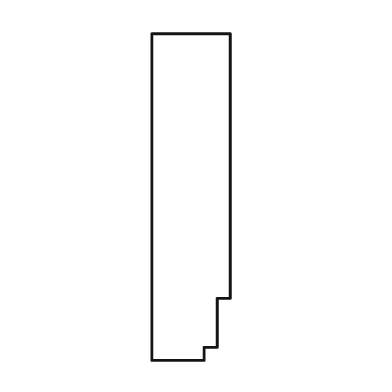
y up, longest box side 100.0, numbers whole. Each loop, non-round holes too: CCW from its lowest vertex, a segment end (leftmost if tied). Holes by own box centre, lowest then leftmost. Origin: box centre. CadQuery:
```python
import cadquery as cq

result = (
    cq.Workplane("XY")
    .moveTo(-12.0, -50.0)
    .lineTo(4.0, -50.0)
    .lineTo(4.0, -46.0)
    .lineTo(8.0, -46.0)
    .lineTo(8.0, -31.0)
    .lineTo(12.0, -31.0)
    .lineTo(12.0, 50.0)
    .lineTo(-12.0, 50.0)
    .close()
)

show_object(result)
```